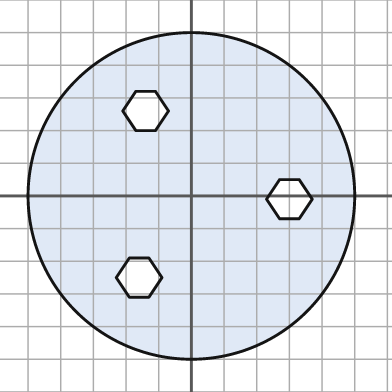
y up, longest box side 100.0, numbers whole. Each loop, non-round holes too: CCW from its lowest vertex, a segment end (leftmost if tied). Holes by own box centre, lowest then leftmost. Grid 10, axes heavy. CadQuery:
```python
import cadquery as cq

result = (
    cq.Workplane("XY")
    .moveTo(0.0, 0.0)
    .circle(50.0)
    .moveTo(-19.0, -31.0)
    .lineTo(-13.0, -31.0)
    .lineTo(-9.0, -25.0)
    .lineTo(-13.0, -19.0)
    .lineTo(-19.0, -19.0)
    .lineTo(-23.0, -25.0)
    .close()
    .moveTo(27.0, -7.0)
    .lineTo(33.0, -7.0)
    .lineTo(37.0, -1.0)
    .lineTo(33.0, 5.0)
    .lineTo(27.0, 5.0)
    .lineTo(23.0, -1.0)
    .close()
    .moveTo(-17.0, 20.0)
    .lineTo(-11.0, 20.0)
    .lineTo(-7.0, 26.0)
    .lineTo(-11.0, 32.0)
    .lineTo(-17.0, 32.0)
    .lineTo(-21.0, 26.0)
    .close()
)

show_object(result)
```